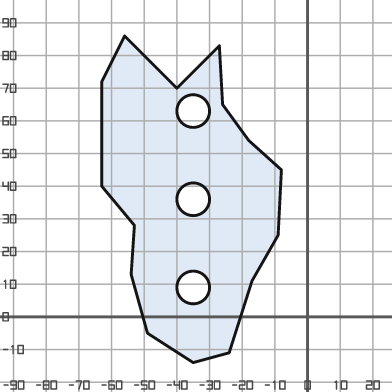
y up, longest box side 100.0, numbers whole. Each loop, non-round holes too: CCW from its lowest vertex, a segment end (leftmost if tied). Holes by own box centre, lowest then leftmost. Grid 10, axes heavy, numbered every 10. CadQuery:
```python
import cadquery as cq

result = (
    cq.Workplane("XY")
    .moveTo(-35.0, -14.0)
    .lineTo(-24.0, -11.0)
    .lineTo(-17.0, 11.0)
    .lineTo(-9.0, 25.0)
    .lineTo(-8.0, 45.0)
    .lineTo(-18.0, 54.0)
    .lineTo(-26.0, 65.0)
    .lineTo(-27.0, 83.0)
    .lineTo(-40.0, 70.0)
    .lineTo(-56.0, 86.0)
    .lineTo(-63.0, 72.0)
    .lineTo(-63.0, 40.0)
    .lineTo(-53.0, 28.0)
    .lineTo(-54.0, 13.0)
    .lineTo(-49.0, -5.0)
    .close()
    .moveTo(-35.0, 9.0)
    .circle(5.0)
    .moveTo(-35.0, 36.0)
    .circle(5.0)
    .moveTo(-35.0, 63.0)
    .circle(5.0)
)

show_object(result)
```